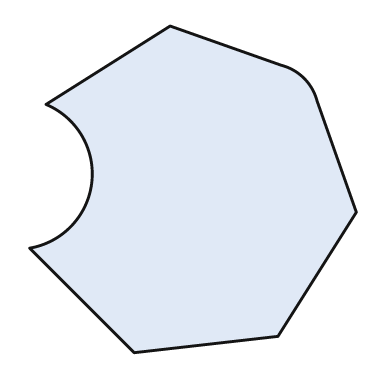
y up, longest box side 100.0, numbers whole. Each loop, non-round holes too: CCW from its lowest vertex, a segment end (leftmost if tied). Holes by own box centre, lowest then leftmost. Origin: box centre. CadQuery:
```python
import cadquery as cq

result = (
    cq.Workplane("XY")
    .moveTo(-18.0, -50.0)
    .lineTo(26.0, -45.0)
    .lineTo(50.0, -7.0)
    .lineTo(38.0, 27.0)
    .threePointArc((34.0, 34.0), (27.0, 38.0))
    .lineTo(-7.0, 50.0)
    .lineTo(-45.0, 26.0)
    .threePointArc((-31.0, 2.0), (-50.0, -18.0))
    .close()
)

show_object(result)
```